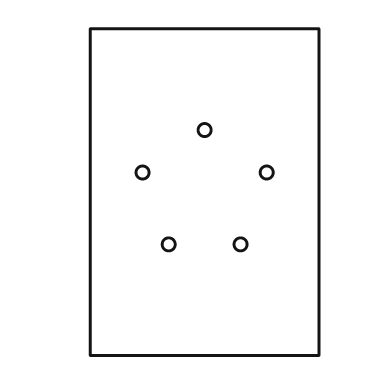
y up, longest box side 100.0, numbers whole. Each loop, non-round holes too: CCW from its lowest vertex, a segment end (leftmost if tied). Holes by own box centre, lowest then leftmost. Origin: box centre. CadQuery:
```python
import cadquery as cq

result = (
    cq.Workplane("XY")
    .moveTo(-35.0, -50.0)
    .lineTo(35.0, -50.0)
    .lineTo(35.0, 50.0)
    .lineTo(-35.0, 50.0)
    .close()
    .moveTo(-11.0, -16.0)
    .circle(2.0)
    .moveTo(11.0, -16.0)
    .circle(2.0)
    .moveTo(-19.0, 6.0)
    .circle(2.0)
    .moveTo(19.0, 6.0)
    .circle(2.0)
    .moveTo(0.0, 19.0)
    .circle(2.0)
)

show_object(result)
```